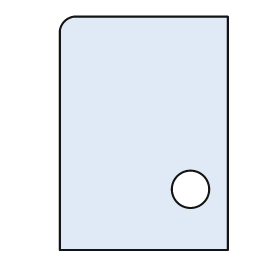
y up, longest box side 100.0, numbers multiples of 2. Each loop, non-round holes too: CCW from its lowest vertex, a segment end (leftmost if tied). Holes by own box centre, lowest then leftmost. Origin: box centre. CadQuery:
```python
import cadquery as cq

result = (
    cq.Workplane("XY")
    .moveTo(-36.0, -50.0)
    .lineTo(36.0, -50.0)
    .lineTo(36.0, 50.0)
    .lineTo(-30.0, 50.0)
    .threePointArc((-34.0, 48.0), (-36.0, 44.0))
    .close()
    .moveTo(20.0, -24.0)
    .circle(8.0)
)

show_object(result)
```